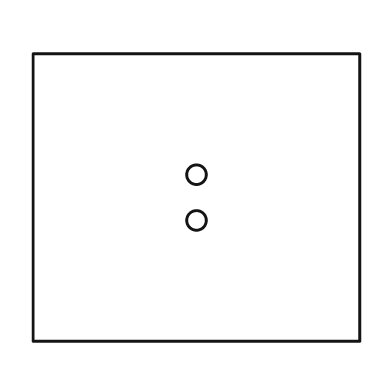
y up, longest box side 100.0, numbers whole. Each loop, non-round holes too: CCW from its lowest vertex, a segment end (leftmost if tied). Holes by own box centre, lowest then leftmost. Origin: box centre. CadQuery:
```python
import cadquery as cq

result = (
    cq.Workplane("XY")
    .moveTo(-50.0, -44.0)
    .lineTo(50.0, -44.0)
    .lineTo(50.0, 44.0)
    .lineTo(-50.0, 44.0)
    .close()
    .moveTo(0.0, -7.0)
    .circle(3.0)
    .moveTo(0.0, 7.0)
    .circle(3.0)
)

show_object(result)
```